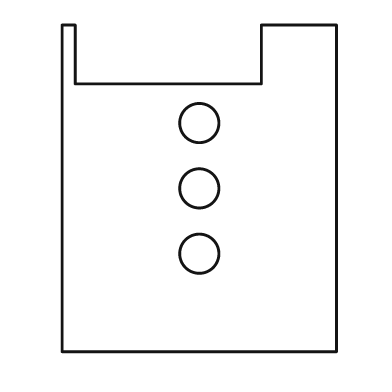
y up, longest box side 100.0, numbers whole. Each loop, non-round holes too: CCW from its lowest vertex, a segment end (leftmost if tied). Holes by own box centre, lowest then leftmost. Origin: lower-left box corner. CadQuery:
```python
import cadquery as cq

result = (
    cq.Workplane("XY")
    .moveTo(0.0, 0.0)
    .lineTo(84.0, 0.0)
    .lineTo(84.0, 100.0)
    .lineTo(61.0, 100.0)
    .lineTo(61.0, 82.0)
    .lineTo(4.0, 82.0)
    .lineTo(4.0, 100.0)
    .lineTo(0.0, 100.0)
    .close()
    .moveTo(42.0, 30.0)
    .circle(6.0)
    .moveTo(42.0, 50.0)
    .circle(6.0)
    .moveTo(42.0, 70.0)
    .circle(6.0)
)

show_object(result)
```